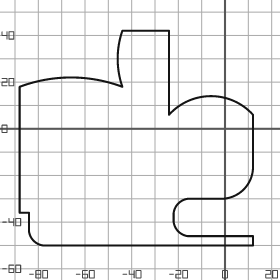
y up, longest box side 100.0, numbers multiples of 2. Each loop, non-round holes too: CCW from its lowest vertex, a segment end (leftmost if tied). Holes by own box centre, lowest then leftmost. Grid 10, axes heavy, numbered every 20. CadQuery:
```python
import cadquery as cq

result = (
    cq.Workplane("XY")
    .moveTo(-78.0, -50.0)
    .lineTo(12.0, -50.0)
    .lineTo(12.0, -46.0)
    .lineTo(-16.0, -46.0)
    .threePointArc((-20.0, -44.0), (-22.0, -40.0))
    .lineTo(-22.0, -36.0)
    .threePointArc((-20.0, -32.0), (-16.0, -30.0))
    .lineTo(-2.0, -30.0)
    .threePointArc((8.0, -26.0), (12.0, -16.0))
    .lineTo(12.0, 6.0)
    .threePointArc((-6.0, 14.0), (-24.0, 6.0))
    .lineTo(-24.0, 42.0)
    .lineTo(-44.0, 42.0)
    .threePointArc((-46.0, 30.0), (-44.0, 18.0))
    .threePointArc((-66.0, 22.0), (-88.0, 18.0))
    .lineTo(-88.0, -36.0)
    .lineTo(-84.0, -36.0)
    .lineTo(-84.0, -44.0)
    .threePointArc((-82.0, -48.0), (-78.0, -50.0))
    .close()
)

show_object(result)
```